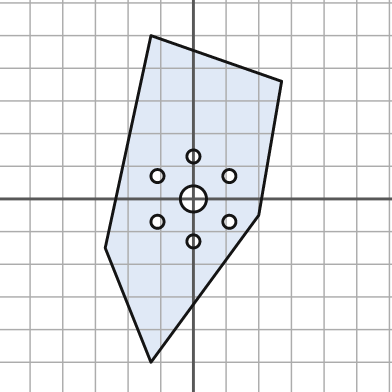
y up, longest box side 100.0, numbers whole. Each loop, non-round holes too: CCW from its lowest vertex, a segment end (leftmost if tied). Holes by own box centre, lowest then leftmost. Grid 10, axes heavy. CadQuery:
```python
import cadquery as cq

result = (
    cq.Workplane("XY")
    .moveTo(-13.0, -50.0)
    .lineTo(20.0, -5.0)
    .lineTo(27.0, 36.0)
    .lineTo(-13.0, 50.0)
    .lineTo(-27.0, -15.0)
    .close()
    .moveTo(0.0, -13.0)
    .circle(2.0)
    .moveTo(-11.0, -7.0)
    .circle(2.0)
    .moveTo(11.0, -7.0)
    .circle(2.0)
    .moveTo(0.0, 0.0)
    .circle(4.0)
    .moveTo(-11.0, 7.0)
    .circle(2.0)
    .moveTo(11.0, 7.0)
    .circle(2.0)
    .moveTo(0.0, 13.0)
    .circle(2.0)
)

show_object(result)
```